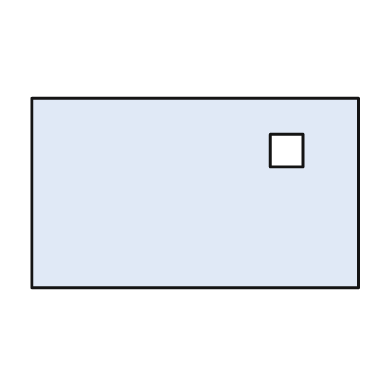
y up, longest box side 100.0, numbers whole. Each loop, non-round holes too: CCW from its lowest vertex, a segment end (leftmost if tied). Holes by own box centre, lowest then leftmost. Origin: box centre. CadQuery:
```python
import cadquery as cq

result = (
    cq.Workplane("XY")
    .moveTo(-50.0, -29.0)
    .lineTo(50.0, -29.0)
    .lineTo(50.0, 29.0)
    .lineTo(-50.0, 29.0)
    .close()
    .moveTo(23.0, 8.0)
    .lineTo(33.0, 8.0)
    .lineTo(33.0, 18.0)
    .lineTo(23.0, 18.0)
    .close()
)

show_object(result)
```